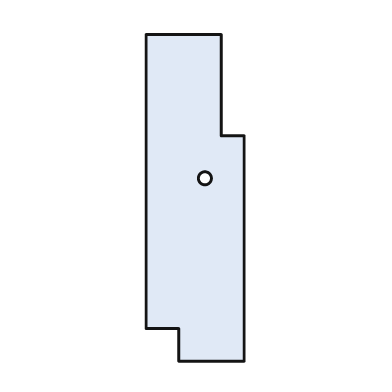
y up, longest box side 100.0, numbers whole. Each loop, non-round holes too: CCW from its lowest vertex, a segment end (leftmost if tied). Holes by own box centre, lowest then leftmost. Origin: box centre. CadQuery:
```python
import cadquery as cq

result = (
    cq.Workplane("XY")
    .moveTo(-5.0, -50.0)
    .lineTo(15.0, -50.0)
    .lineTo(15.0, 19.0)
    .lineTo(8.0, 19.0)
    .lineTo(8.0, 50.0)
    .lineTo(-15.0, 50.0)
    .lineTo(-15.0, -40.0)
    .lineTo(-5.0, -40.0)
    .close()
    .moveTo(3.0, 6.0)
    .circle(2.0)
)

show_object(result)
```